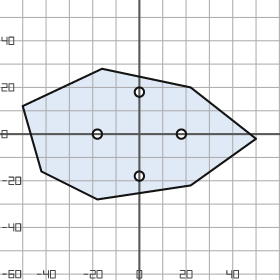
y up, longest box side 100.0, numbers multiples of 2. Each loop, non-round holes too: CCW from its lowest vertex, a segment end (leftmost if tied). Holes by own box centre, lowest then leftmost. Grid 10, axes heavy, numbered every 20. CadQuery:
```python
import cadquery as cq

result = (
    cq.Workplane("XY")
    .moveTo(-18.0, -28.0)
    .lineTo(22.0, -22.0)
    .lineTo(50.0, -2.0)
    .lineTo(22.0, 20.0)
    .lineTo(-16.0, 28.0)
    .lineTo(-50.0, 12.0)
    .lineTo(-42.0, -16.0)
    .close()
    .moveTo(0.0, -18.0)
    .circle(2.0)
    .moveTo(-18.0, 0.0)
    .circle(2.0)
    .moveTo(18.0, 0.0)
    .circle(2.0)
    .moveTo(0.0, 18.0)
    .circle(2.0)
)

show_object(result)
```